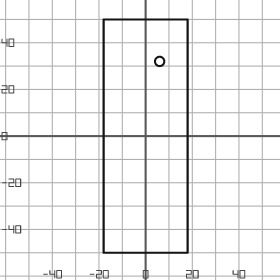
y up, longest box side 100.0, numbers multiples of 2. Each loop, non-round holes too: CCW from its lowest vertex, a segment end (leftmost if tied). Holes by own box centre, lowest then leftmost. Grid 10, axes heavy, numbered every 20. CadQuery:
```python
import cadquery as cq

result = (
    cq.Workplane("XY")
    .moveTo(-18.0, -50.0)
    .lineTo(18.0, -50.0)
    .lineTo(18.0, 50.0)
    .lineTo(-18.0, 50.0)
    .close()
    .moveTo(6.0, 32.0)
    .circle(2.0)
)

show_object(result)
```